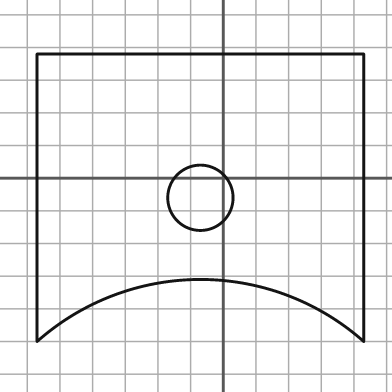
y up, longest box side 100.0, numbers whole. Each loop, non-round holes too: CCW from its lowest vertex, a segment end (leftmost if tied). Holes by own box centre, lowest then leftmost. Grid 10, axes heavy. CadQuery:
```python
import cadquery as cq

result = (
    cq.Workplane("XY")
    .moveTo(-57.0, -50.0)
    .threePointArc((-7.0, -31.0), (43.0, -50.0))
    .lineTo(43.0, 38.0)
    .lineTo(-57.0, 38.0)
    .close()
    .moveTo(-7.0, -6.0)
    .circle(10.0)
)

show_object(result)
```